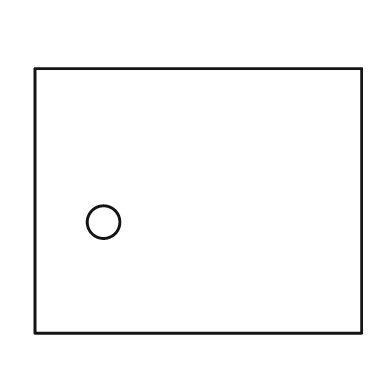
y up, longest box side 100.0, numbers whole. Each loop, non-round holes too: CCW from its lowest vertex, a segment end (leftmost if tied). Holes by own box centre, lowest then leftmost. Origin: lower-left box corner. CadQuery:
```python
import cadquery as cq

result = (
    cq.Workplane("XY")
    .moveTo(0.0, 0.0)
    .lineTo(100.0, 0.0)
    .lineTo(100.0, 81.0)
    .lineTo(0.0, 81.0)
    .close()
    .moveTo(21.0, 34.0)
    .circle(5.0)
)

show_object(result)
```